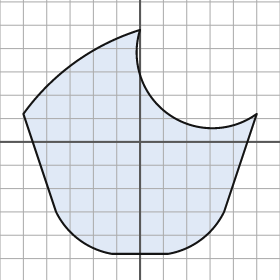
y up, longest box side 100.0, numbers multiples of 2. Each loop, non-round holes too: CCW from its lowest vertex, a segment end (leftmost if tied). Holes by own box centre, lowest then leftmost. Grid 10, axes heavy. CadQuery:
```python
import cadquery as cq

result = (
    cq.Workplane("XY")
    .moveTo(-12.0, -48.0)
    .lineTo(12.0, -48.0)
    .threePointArc((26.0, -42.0), (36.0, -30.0))
    .lineTo(50.0, 12.0)
    .threePointArc((12.0, 12.0), (0.0, 48.0))
    .threePointArc((-28.0, 34.0), (-50.0, 12.0))
    .lineTo(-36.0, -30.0)
    .threePointArc((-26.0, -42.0), (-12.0, -48.0))
    .close()
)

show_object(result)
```